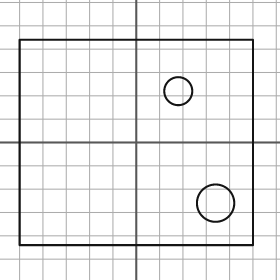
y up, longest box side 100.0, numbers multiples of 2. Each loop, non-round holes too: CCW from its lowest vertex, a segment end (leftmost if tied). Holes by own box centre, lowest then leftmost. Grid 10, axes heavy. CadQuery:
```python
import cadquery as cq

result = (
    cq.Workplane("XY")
    .moveTo(-50.0, -44.0)
    .lineTo(50.0, -44.0)
    .lineTo(50.0, 44.0)
    .lineTo(-50.0, 44.0)
    .close()
    .moveTo(34.0, -26.0)
    .circle(8.0)
    .moveTo(18.0, 22.0)
    .circle(6.0)
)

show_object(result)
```